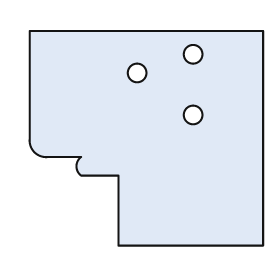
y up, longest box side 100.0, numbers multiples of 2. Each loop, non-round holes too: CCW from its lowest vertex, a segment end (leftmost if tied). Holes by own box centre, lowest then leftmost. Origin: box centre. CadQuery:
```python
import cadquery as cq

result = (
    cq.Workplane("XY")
    .moveTo(-12.0, -46.0)
    .lineTo(50.0, -46.0)
    .lineTo(50.0, 46.0)
    .lineTo(-50.0, 46.0)
    .lineTo(-50.0, 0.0)
    .threePointArc((-48.0, -6.0), (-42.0, -8.0))
    .lineTo(-28.0, -8.0)
    .threePointArc((-30.0, -12.0), (-28.0, -16.0))
    .lineTo(-12.0, -16.0)
    .close()
    .moveTo(20.0, 10.0)
    .circle(4.0)
    .moveTo(-4.0, 28.0)
    .circle(4.0)
    .moveTo(20.0, 36.0)
    .circle(4.0)
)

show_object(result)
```